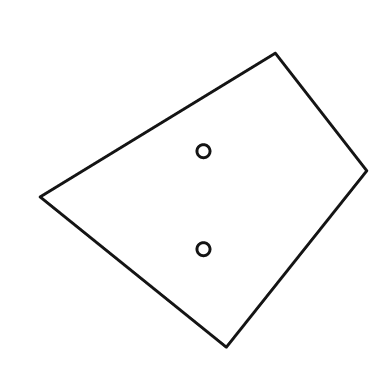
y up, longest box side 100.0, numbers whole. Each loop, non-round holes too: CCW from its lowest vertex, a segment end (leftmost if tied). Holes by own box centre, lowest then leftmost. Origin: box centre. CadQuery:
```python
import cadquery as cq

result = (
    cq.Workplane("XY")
    .moveTo(7.0, -45.0)
    .lineTo(50.0, 9.0)
    .lineTo(22.0, 45.0)
    .lineTo(-50.0, 1.0)
    .close()
    .moveTo(0.0, -15.0)
    .circle(2.0)
    .moveTo(0.0, 15.0)
    .circle(2.0)
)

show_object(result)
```